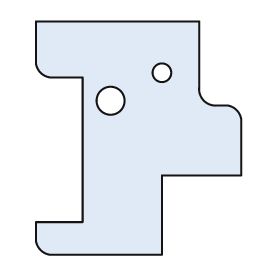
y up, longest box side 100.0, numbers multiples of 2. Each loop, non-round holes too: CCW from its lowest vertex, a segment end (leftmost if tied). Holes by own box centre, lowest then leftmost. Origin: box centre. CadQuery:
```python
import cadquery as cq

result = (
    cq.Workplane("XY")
    .moveTo(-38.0, -50.0)
    .lineTo(10.0, -50.0)
    .lineTo(10.0, -16.0)
    .lineTo(44.0, -16.0)
    .lineTo(44.0, 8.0)
    .threePointArc((42.0, 12.0), (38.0, 14.0))
    .lineTo(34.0, 14.0)
    .threePointArc((28.0, 16.0), (26.0, 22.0))
    .lineTo(26.0, 50.0)
    .lineTo(-44.0, 50.0)
    .lineTo(-44.0, 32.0)
    .threePointArc((-42.0, 28.0), (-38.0, 26.0))
    .lineTo(-24.0, 26.0)
    .lineTo(-24.0, -36.0)
    .lineTo(-44.0, -36.0)
    .lineTo(-44.0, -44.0)
    .threePointArc((-42.0, -48.0), (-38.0, -50.0))
    .close()
    .moveTo(-12.0, 16.0)
    .circle(6.0)
    .moveTo(10.0, 28.0)
    .circle(4.0)
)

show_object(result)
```